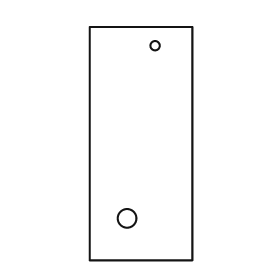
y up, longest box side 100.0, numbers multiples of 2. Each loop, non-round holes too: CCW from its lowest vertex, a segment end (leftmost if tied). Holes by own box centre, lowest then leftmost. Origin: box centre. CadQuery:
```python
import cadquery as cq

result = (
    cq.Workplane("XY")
    .moveTo(-22.0, -50.0)
    .lineTo(22.0, -50.0)
    .lineTo(22.0, 50.0)
    .lineTo(-22.0, 50.0)
    .close()
    .moveTo(-6.0, -32.0)
    .circle(4.0)
    .moveTo(6.0, 42.0)
    .circle(2.0)
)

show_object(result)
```